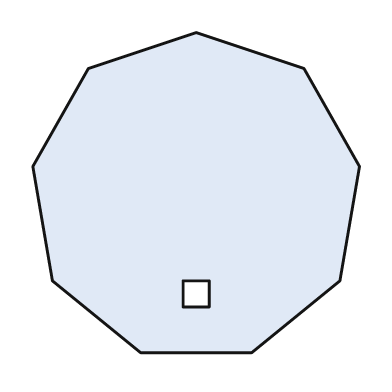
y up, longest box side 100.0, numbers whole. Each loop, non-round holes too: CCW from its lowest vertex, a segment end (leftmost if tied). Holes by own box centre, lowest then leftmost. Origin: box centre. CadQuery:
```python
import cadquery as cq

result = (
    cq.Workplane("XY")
    .moveTo(-17.0, -49.0)
    .lineTo(17.0, -49.0)
    .lineTo(44.0, -27.0)
    .lineTo(50.0, 8.0)
    .lineTo(33.0, 38.0)
    .lineTo(0.0, 49.0)
    .lineTo(-33.0, 38.0)
    .lineTo(-50.0, 8.0)
    .lineTo(-44.0, -27.0)
    .close()
    .moveTo(-4.0, -35.0)
    .lineTo(4.0, -35.0)
    .lineTo(4.0, -27.0)
    .lineTo(-4.0, -27.0)
    .close()
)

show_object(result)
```